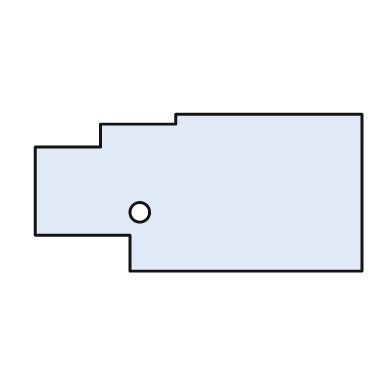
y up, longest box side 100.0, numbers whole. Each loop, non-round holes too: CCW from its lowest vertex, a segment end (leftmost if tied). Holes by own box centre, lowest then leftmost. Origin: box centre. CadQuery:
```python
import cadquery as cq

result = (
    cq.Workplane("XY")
    .moveTo(-21.0, -24.0)
    .lineTo(50.0, -24.0)
    .lineTo(50.0, 24.0)
    .lineTo(-7.0, 24.0)
    .lineTo(-7.0, 21.0)
    .lineTo(-30.0, 21.0)
    .lineTo(-30.0, 14.0)
    .lineTo(-50.0, 14.0)
    .lineTo(-50.0, -13.0)
    .lineTo(-21.0, -13.0)
    .close()
    .moveTo(-18.0, -6.0)
    .circle(3.0)
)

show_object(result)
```